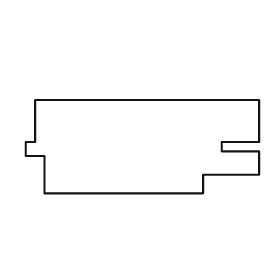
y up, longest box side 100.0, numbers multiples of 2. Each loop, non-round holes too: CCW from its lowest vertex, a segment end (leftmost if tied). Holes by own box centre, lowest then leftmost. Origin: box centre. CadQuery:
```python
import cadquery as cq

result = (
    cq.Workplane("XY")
    .moveTo(-42.0, -20.0)
    .lineTo(26.0, -20.0)
    .lineTo(26.0, -12.0)
    .lineTo(50.0, -12.0)
    .lineTo(50.0, -2.0)
    .lineTo(34.0, -2.0)
    .lineTo(34.0, 2.0)
    .lineTo(50.0, 2.0)
    .lineTo(50.0, 20.0)
    .lineTo(-46.0, 20.0)
    .lineTo(-46.0, 2.0)
    .lineTo(-50.0, 2.0)
    .lineTo(-50.0, -4.0)
    .lineTo(-42.0, -4.0)
    .close()
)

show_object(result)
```